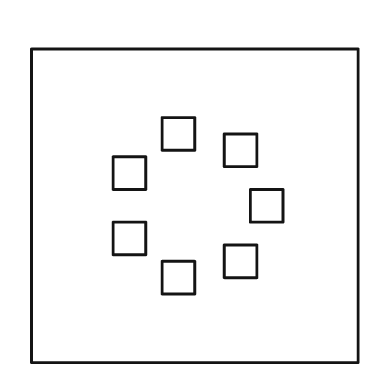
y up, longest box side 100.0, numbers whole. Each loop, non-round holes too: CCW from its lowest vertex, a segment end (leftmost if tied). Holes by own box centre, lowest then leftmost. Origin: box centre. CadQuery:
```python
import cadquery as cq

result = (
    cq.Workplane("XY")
    .moveTo(-50.0, -48.0)
    .lineTo(50.0, -48.0)
    .lineTo(50.0, 48.0)
    .lineTo(-50.0, 48.0)
    .close()
    .moveTo(-10.0, -27.0)
    .lineTo(0.0, -27.0)
    .lineTo(0.0, -17.0)
    .lineTo(-10.0, -17.0)
    .close()
    .moveTo(9.0, -22.0)
    .lineTo(19.0, -22.0)
    .lineTo(19.0, -12.0)
    .lineTo(9.0, -12.0)
    .close()
    .moveTo(-25.0, -15.0)
    .lineTo(-15.0, -15.0)
    .lineTo(-15.0, -5.0)
    .lineTo(-25.0, -5.0)
    .close()
    .moveTo(17.0, -5.0)
    .lineTo(27.0, -5.0)
    .lineTo(27.0, 5.0)
    .lineTo(17.0, 5.0)
    .close()
    .moveTo(-25.0, 5.0)
    .lineTo(-15.0, 5.0)
    .lineTo(-15.0, 15.0)
    .lineTo(-25.0, 15.0)
    .close()
    .moveTo(9.0, 12.0)
    .lineTo(19.0, 12.0)
    .lineTo(19.0, 22.0)
    .lineTo(9.0, 22.0)
    .close()
    .moveTo(-10.0, 17.0)
    .lineTo(0.0, 17.0)
    .lineTo(0.0, 27.0)
    .lineTo(-10.0, 27.0)
    .close()
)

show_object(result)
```